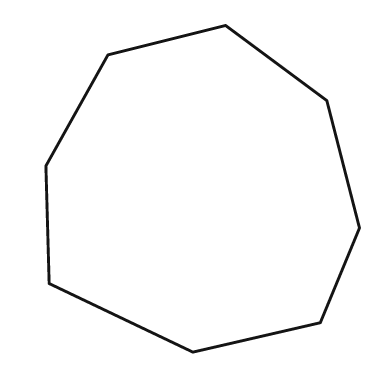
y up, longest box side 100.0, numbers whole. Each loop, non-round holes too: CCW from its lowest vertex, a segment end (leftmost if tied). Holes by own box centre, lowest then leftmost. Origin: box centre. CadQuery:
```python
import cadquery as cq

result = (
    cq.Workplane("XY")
    .moveTo(-3.0, -50.0)
    .lineTo(36.0, -41.0)
    .lineTo(48.0, -12.0)
    .lineTo(38.0, 27.0)
    .lineTo(7.0, 50.0)
    .lineTo(-29.0, 41.0)
    .lineTo(-48.0, 7.0)
    .lineTo(-47.0, -29.0)
    .close()
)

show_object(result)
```